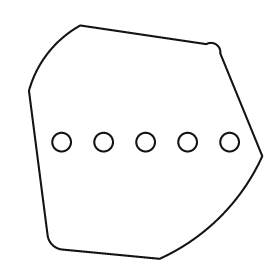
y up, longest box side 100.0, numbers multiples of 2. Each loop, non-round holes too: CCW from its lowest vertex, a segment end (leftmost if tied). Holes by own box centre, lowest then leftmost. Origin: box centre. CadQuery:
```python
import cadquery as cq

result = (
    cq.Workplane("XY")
    .moveTo(6.0, -50.0)
    .threePointArc((32.0, -32.0), (50.0, -6.0))
    .lineTo(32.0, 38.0)
    .threePointArc((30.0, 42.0), (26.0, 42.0))
    .lineTo(-28.0, 50.0)
    .threePointArc((-42.0, 38.0), (-50.0, 22.0))
    .lineTo(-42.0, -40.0)
    .threePointArc((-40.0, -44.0), (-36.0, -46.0))
    .close()
    .moveTo(-36.0, 0.0)
    .circle(4.0)
    .moveTo(-18.0, 0.0)
    .circle(4.0)
    .moveTo(0.0, 0.0)
    .circle(4.0)
    .moveTo(18.0, 0.0)
    .circle(4.0)
    .moveTo(36.0, 0.0)
    .circle(4.0)
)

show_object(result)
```